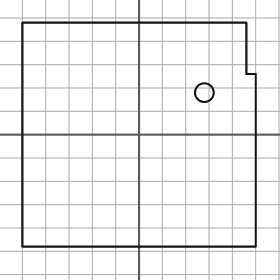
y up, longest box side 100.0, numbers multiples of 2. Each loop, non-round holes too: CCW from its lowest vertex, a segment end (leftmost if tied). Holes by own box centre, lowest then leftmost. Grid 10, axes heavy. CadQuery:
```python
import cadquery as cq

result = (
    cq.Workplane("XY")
    .moveTo(-50.0, -48.0)
    .lineTo(50.0, -48.0)
    .lineTo(50.0, 26.0)
    .lineTo(46.0, 26.0)
    .lineTo(46.0, 48.0)
    .lineTo(-50.0, 48.0)
    .close()
    .moveTo(28.0, 18.0)
    .circle(4.0)
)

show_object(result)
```